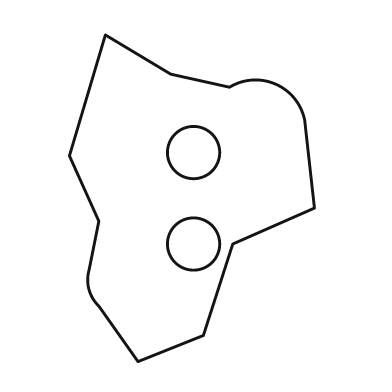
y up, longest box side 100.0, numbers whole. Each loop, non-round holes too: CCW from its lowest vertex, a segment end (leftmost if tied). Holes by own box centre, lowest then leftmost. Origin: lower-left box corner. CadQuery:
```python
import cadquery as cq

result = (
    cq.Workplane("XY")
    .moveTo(21.0, 0.0)
    .lineTo(41.0, 8.0)
    .lineTo(50.0, 36.0)
    .lineTo(75.0, 47.0)
    .lineTo(72.0, 74.0)
    .threePointArc((63.0, 85.0), (49.0, 84.0))
    .lineTo(31.0, 88.0)
    .lineTo(11.0, 100.0)
    .lineTo(0.0, 63.0)
    .lineTo(9.0, 43.0)
    .lineTo(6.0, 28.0)
    .threePointArc((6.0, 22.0), (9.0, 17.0))
    .close()
    .moveTo(38.0, 36.0)
    .circle(8.0)
    .moveTo(38.0, 64.0)
    .circle(8.0)
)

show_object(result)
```